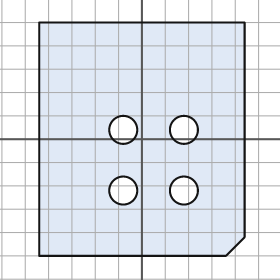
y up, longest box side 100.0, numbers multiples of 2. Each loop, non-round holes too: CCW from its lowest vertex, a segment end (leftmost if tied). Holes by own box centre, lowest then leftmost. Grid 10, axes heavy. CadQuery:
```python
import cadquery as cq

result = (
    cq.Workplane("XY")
    .moveTo(-44.0, -50.0)
    .lineTo(36.0, -50.0)
    .lineTo(44.0, -42.0)
    .lineTo(44.0, 50.0)
    .lineTo(-44.0, 50.0)
    .close()
    .moveTo(-8.0, -22.0)
    .circle(6.0)
    .moveTo(18.0, -22.0)
    .circle(6.0)
    .moveTo(-8.0, 4.0)
    .circle(6.0)
    .moveTo(18.0, 4.0)
    .circle(6.0)
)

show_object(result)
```